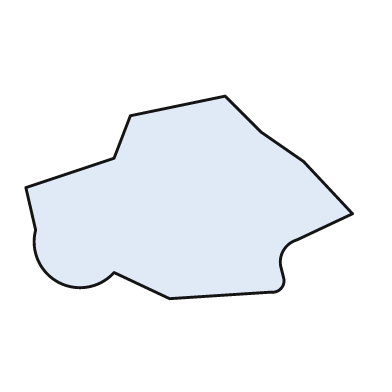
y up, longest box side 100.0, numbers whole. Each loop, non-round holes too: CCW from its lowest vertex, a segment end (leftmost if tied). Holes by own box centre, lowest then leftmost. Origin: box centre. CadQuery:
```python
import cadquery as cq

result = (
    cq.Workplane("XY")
    .moveTo(-6.0, -31.0)
    .lineTo(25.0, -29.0)
    .threePointArc((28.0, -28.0), (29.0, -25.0))
    .lineTo(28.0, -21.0)
    .threePointArc((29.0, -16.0), (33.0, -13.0))
    .lineTo(50.0, -5.0)
    .lineTo(35.0, 11.0)
    .lineTo(22.0, 20.0)
    .lineTo(11.0, 31.0)
    .lineTo(-18.0, 25.0)
    .lineTo(-23.0, 12.0)
    .lineTo(-50.0, 3.0)
    .lineTo(-47.0, -10.0)
    .threePointArc((-40.0, -26.0), (-23.0, -23.0))
    .close()
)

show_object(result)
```